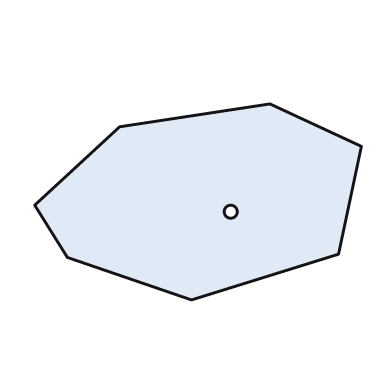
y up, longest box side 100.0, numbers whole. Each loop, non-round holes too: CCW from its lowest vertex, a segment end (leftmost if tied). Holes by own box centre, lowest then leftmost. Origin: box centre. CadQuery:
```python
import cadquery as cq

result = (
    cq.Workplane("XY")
    .moveTo(-2.0, -30.0)
    .lineTo(43.0, -16.0)
    .lineTo(50.0, 17.0)
    .lineTo(22.0, 30.0)
    .lineTo(-24.0, 23.0)
    .lineTo(-50.0, -1.0)
    .lineTo(-40.0, -17.0)
    .close()
    .moveTo(10.0, -3.0)
    .circle(2.0)
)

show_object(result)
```